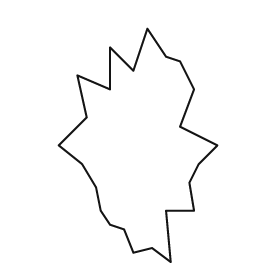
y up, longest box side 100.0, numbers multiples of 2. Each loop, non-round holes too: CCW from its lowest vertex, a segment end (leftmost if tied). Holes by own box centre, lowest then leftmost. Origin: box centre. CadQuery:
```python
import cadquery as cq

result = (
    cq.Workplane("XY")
    .moveTo(14.0, -50.0)
    .lineTo(12.0, -28.0)
    .lineTo(24.0, -28.0)
    .lineTo(22.0, -16.0)
    .lineTo(26.0, -8.0)
    .lineTo(34.0, 0.0)
    .lineTo(18.0, 8.0)
    .lineTo(24.0, 24.0)
    .lineTo(18.0, 36.0)
    .lineTo(12.0, 38.0)
    .lineTo(4.0, 50.0)
    .lineTo(-2.0, 32.0)
    .lineTo(-12.0, 42.0)
    .lineTo(-12.0, 24.0)
    .lineTo(-26.0, 30.0)
    .lineTo(-22.0, 12.0)
    .lineTo(-34.0, 0.0)
    .lineTo(-24.0, -8.0)
    .lineTo(-18.0, -18.0)
    .lineTo(-16.0, -28.0)
    .lineTo(-12.0, -34.0)
    .lineTo(-6.0, -36.0)
    .lineTo(-2.0, -46.0)
    .lineTo(6.0, -44.0)
    .close()
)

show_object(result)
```